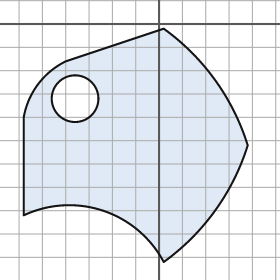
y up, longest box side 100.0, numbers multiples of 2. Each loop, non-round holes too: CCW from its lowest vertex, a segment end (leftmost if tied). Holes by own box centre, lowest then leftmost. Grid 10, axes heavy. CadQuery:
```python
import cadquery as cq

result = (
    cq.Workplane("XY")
    .moveTo(2.0, -102.0)
    .threePointArc((24.0, -80.0), (38.0, -52.0))
    .threePointArc((24.0, -24.0), (2.0, -2.0))
    .lineTo(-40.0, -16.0)
    .threePointArc((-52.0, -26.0), (-58.0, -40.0))
    .lineTo(-58.0, -82.0)
    .threePointArc((-24.0, -80.0), (2.0, -102.0))
    .close()
    .moveTo(-36.0, -32.0)
    .circle(10.0)
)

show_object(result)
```